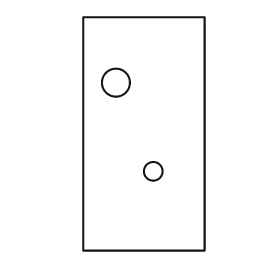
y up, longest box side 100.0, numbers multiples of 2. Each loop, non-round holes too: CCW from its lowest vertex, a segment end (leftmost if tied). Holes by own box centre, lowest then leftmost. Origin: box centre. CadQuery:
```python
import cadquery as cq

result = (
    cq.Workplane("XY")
    .moveTo(-26.0, -50.0)
    .lineTo(26.0, -50.0)
    .lineTo(26.0, 50.0)
    .lineTo(-26.0, 50.0)
    .close()
    .moveTo(4.0, -16.0)
    .circle(4.0)
    .moveTo(-12.0, 22.0)
    .circle(6.0)
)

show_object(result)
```